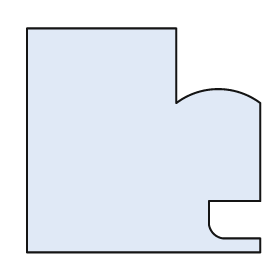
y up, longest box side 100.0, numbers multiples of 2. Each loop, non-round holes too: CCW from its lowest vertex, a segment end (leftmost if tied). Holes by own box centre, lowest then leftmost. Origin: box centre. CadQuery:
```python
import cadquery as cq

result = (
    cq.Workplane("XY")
    .moveTo(-50.0, -48.0)
    .lineTo(50.0, -48.0)
    .lineTo(50.0, -42.0)
    .lineTo(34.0, -42.0)
    .threePointArc((30.0, -40.0), (28.0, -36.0))
    .lineTo(28.0, -26.0)
    .lineTo(50.0, -26.0)
    .lineTo(50.0, 16.0)
    .threePointArc((32.0, 22.0), (14.0, 16.0))
    .lineTo(14.0, 48.0)
    .lineTo(-50.0, 48.0)
    .close()
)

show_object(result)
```